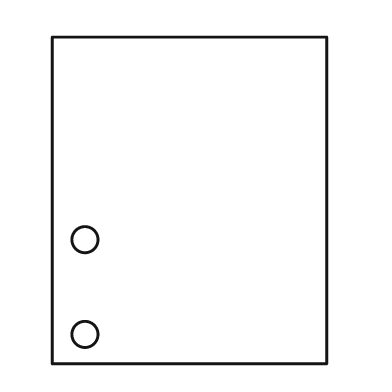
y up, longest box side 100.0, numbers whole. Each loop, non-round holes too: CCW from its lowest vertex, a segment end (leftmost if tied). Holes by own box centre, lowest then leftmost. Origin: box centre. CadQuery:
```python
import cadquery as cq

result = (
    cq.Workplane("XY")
    .moveTo(-42.0, -50.0)
    .lineTo(42.0, -50.0)
    .lineTo(42.0, 50.0)
    .lineTo(-42.0, 50.0)
    .close()
    .moveTo(-32.0, -41.0)
    .circle(4.0)
    .moveTo(-32.0, -12.0)
    .circle(4.0)
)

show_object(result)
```